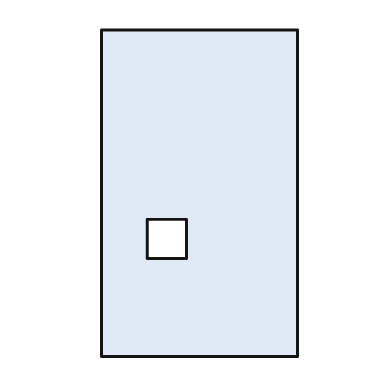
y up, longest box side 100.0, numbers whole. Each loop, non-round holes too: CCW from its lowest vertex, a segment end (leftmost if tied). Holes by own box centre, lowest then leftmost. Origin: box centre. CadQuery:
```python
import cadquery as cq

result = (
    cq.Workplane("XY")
    .moveTo(-30.0, -50.0)
    .lineTo(30.0, -50.0)
    .lineTo(30.0, 50.0)
    .lineTo(-30.0, 50.0)
    .close()
    .moveTo(-16.0, -20.0)
    .lineTo(-4.0, -20.0)
    .lineTo(-4.0, -8.0)
    .lineTo(-16.0, -8.0)
    .close()
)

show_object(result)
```